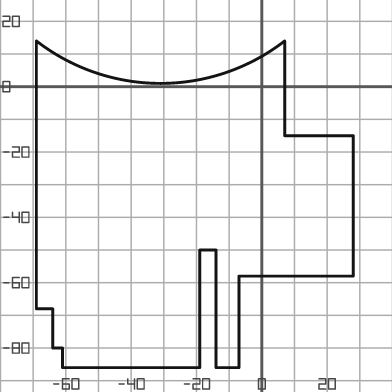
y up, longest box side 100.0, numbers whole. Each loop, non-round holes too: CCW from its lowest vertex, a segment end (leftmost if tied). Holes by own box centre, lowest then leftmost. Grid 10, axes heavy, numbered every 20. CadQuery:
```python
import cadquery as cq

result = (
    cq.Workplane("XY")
    .moveTo(-61.0, -86.0)
    .lineTo(-19.0, -86.0)
    .lineTo(-19.0, -50.0)
    .lineTo(-14.0, -50.0)
    .lineTo(-14.0, -86.0)
    .lineTo(-7.0, -86.0)
    .lineTo(-7.0, -58.0)
    .lineTo(28.0, -58.0)
    .lineTo(28.0, -15.0)
    .lineTo(7.0, -15.0)
    .lineTo(7.0, 14.0)
    .threePointArc((-31.0, 1.0), (-69.0, 14.0))
    .lineTo(-69.0, -68.0)
    .lineTo(-64.0, -68.0)
    .lineTo(-64.0, -80.0)
    .lineTo(-61.0, -80.0)
    .close()
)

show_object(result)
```